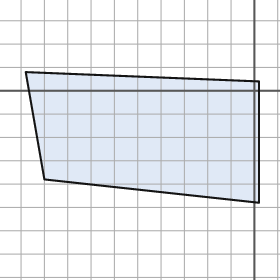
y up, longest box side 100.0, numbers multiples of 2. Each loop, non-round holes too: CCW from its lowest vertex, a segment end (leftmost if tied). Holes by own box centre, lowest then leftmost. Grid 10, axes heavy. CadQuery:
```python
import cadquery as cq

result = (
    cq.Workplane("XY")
    .moveTo(2.0, -48.0)
    .lineTo(2.0, 4.0)
    .lineTo(-98.0, 8.0)
    .lineTo(-90.0, -38.0)
    .close()
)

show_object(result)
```